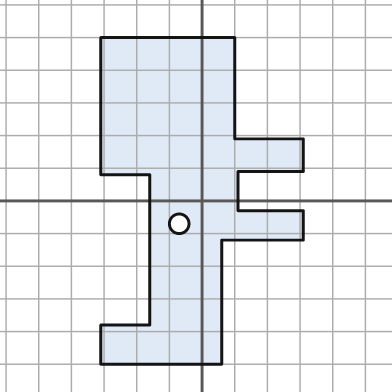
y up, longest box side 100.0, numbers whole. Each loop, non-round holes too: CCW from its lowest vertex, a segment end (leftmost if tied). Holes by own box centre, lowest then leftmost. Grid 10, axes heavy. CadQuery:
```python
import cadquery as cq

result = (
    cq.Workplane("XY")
    .moveTo(-31.0, -50.0)
    .lineTo(6.0, -50.0)
    .lineTo(6.0, -12.0)
    .lineTo(31.0, -12.0)
    .lineTo(31.0, -3.0)
    .lineTo(11.0, -3.0)
    .lineTo(11.0, 9.0)
    .lineTo(31.0, 9.0)
    .lineTo(31.0, 19.0)
    .lineTo(10.0, 19.0)
    .lineTo(10.0, 50.0)
    .lineTo(-31.0, 50.0)
    .lineTo(-31.0, 8.0)
    .lineTo(-16.0, 8.0)
    .lineTo(-16.0, -38.0)
    .lineTo(-31.0, -38.0)
    .close()
    .moveTo(-7.0, -7.0)
    .circle(3.0)
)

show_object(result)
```